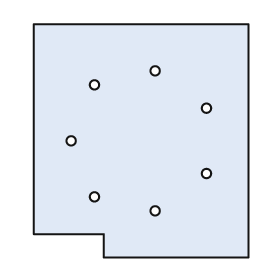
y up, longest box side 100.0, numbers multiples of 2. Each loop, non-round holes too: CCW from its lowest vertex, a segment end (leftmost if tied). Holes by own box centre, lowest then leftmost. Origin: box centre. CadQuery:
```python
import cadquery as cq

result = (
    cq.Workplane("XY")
    .moveTo(-16.0, -50.0)
    .lineTo(46.0, -50.0)
    .lineTo(46.0, 50.0)
    .lineTo(-46.0, 50.0)
    .lineTo(-46.0, -40.0)
    .lineTo(-16.0, -40.0)
    .close()
    .moveTo(6.0, -30.0)
    .circle(2.0)
    .moveTo(-20.0, -24.0)
    .circle(2.0)
    .moveTo(28.0, -14.0)
    .circle(2.0)
    .moveTo(-30.0, 0.0)
    .circle(2.0)
    .moveTo(28.0, 14.0)
    .circle(2.0)
    .moveTo(-20.0, 24.0)
    .circle(2.0)
    .moveTo(6.0, 30.0)
    .circle(2.0)
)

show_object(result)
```